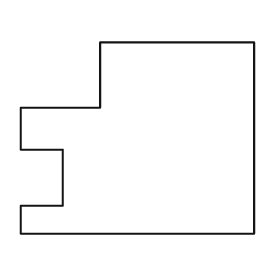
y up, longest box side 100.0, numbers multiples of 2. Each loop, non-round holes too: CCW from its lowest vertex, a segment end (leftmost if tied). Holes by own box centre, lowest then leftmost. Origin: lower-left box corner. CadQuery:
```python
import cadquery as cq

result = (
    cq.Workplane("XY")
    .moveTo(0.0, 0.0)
    .lineTo(100.0, 0.0)
    .lineTo(100.0, 82.0)
    .lineTo(34.0, 82.0)
    .lineTo(34.0, 54.0)
    .lineTo(0.0, 54.0)
    .lineTo(0.0, 36.0)
    .lineTo(18.0, 36.0)
    .lineTo(18.0, 12.0)
    .lineTo(0.0, 12.0)
    .close()
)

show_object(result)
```